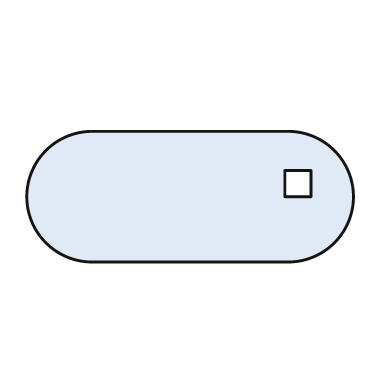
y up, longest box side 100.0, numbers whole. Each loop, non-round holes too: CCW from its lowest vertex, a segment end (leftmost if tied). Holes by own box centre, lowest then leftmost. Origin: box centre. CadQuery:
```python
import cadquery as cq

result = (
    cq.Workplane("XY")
    .moveTo(-30.0, -20.0)
    .lineTo(30.0, -20.0)
    .threePointArc((50.0, 0.0), (30.0, 20.0))
    .lineTo(-30.0, 20.0)
    .threePointArc((-50.0, 0.0), (-30.0, -20.0))
    .close()
    .moveTo(29.0, 0.0)
    .lineTo(37.0, 0.0)
    .lineTo(37.0, 8.0)
    .lineTo(29.0, 8.0)
    .close()
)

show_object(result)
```